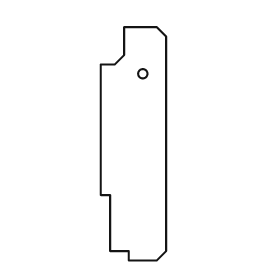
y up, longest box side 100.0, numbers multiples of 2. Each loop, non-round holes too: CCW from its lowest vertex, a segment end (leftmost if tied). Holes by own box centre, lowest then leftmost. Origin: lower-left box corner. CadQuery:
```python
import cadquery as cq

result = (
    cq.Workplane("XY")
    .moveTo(12.0, 0.0)
    .lineTo(24.0, 0.0)
    .lineTo(28.0, 4.0)
    .lineTo(28.0, 96.0)
    .lineTo(24.0, 100.0)
    .lineTo(10.0, 100.0)
    .lineTo(10.0, 88.0)
    .lineTo(6.0, 84.0)
    .lineTo(0.0, 84.0)
    .lineTo(0.0, 28.0)
    .lineTo(4.0, 28.0)
    .lineTo(4.0, 4.0)
    .lineTo(12.0, 4.0)
    .close()
    .moveTo(18.0, 80.0)
    .circle(2.0)
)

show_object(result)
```